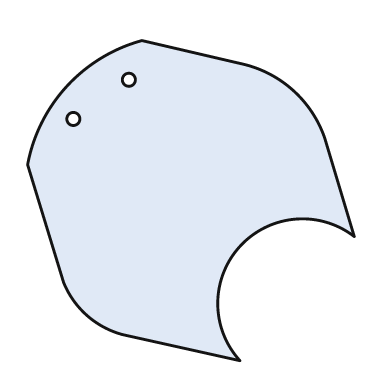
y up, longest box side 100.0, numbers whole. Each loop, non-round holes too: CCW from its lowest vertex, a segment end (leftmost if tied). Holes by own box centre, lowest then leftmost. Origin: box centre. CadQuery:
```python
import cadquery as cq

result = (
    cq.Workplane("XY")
    .moveTo(15.0, -49.0)
    .threePointArc((15.0, -14.0), (50.0, -11.0))
    .lineTo(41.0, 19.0)
    .threePointArc((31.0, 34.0), (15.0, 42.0))
    .lineTo(-15.0, 49.0)
    .threePointArc((-38.0, 35.0), (-50.0, 11.0))
    .lineTo(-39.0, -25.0)
    .threePointArc((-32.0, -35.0), (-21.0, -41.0))
    .close()
    .moveTo(-36.0, 25.0)
    .circle(2.0)
    .moveTo(-19.0, 37.0)
    .circle(2.0)
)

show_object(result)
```